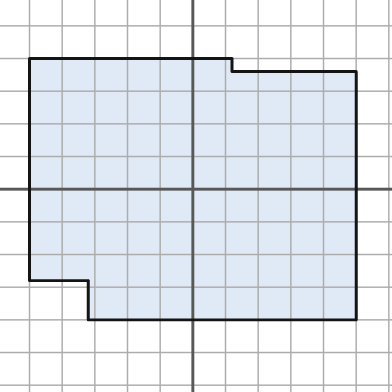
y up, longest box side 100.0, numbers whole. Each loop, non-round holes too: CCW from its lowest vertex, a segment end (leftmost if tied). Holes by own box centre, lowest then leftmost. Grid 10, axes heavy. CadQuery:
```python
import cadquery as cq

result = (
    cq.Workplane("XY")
    .moveTo(-32.0, -40.0)
    .lineTo(50.0, -40.0)
    .lineTo(50.0, 36.0)
    .lineTo(12.0, 36.0)
    .lineTo(12.0, 40.0)
    .lineTo(-50.0, 40.0)
    .lineTo(-50.0, -28.0)
    .lineTo(-32.0, -28.0)
    .close()
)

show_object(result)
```